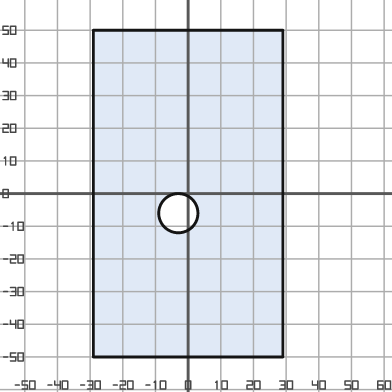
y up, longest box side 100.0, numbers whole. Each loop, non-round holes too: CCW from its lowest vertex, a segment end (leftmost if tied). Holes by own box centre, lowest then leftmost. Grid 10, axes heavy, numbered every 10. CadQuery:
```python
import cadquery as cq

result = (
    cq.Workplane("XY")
    .moveTo(-29.0, -50.0)
    .lineTo(29.0, -50.0)
    .lineTo(29.0, 50.0)
    .lineTo(-29.0, 50.0)
    .close()
    .moveTo(-3.0, -6.0)
    .circle(6.0)
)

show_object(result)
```